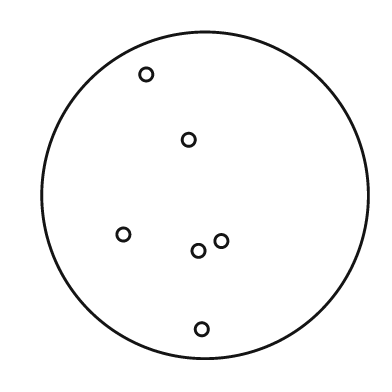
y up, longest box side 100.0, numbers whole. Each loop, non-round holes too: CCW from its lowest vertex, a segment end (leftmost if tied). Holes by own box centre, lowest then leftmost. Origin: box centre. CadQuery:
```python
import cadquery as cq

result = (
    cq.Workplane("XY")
    .moveTo(0.0, 0.0)
    .circle(50.0)
    .moveTo(-1.0, -41.0)
    .circle(2.0)
    .moveTo(-2.0, -17.0)
    .circle(2.0)
    .moveTo(5.0, -14.0)
    .circle(2.0)
    .moveTo(-25.0, -12.0)
    .circle(2.0)
    .moveTo(-5.0, 17.0)
    .circle(2.0)
    .moveTo(-18.0, 37.0)
    .circle(2.0)
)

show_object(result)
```